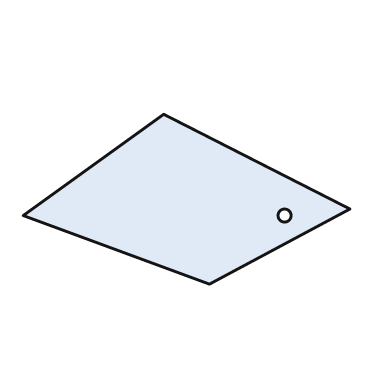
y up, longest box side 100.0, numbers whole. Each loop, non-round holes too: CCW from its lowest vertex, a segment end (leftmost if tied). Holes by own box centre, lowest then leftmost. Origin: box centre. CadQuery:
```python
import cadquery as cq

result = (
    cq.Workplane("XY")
    .moveTo(7.0, -26.0)
    .lineTo(50.0, -3.0)
    .lineTo(-7.0, 26.0)
    .lineTo(-50.0, -5.0)
    .close()
    .moveTo(30.0, -5.0)
    .circle(2.0)
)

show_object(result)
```